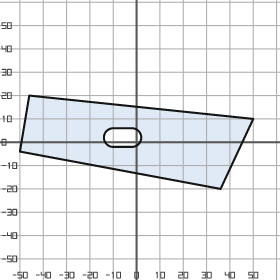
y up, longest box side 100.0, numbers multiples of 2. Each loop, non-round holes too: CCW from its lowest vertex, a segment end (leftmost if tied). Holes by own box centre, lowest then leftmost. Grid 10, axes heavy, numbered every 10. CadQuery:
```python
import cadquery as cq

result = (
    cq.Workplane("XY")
    .moveTo(36.0, -20.0)
    .lineTo(50.0, 10.0)
    .lineTo(-46.0, 20.0)
    .lineTo(-50.0, -4.0)
    .close()
    .moveTo(-10.0, -2.0)
    .lineTo(-2.0, -2.0)
    .threePointArc((2.0, 2.0), (-2.0, 6.0))
    .lineTo(-10.0, 6.0)
    .threePointArc((-14.0, 2.0), (-10.0, -2.0))
    .close()
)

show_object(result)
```